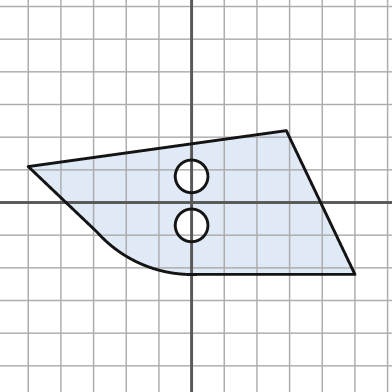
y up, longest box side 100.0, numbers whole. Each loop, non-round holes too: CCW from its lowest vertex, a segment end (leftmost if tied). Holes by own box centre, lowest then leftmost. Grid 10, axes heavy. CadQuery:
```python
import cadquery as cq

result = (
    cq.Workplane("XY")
    .moveTo(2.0, -22.0)
    .lineTo(50.0, -22.0)
    .lineTo(29.0, 22.0)
    .lineTo(-50.0, 11.0)
    .lineTo(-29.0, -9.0)
    .threePointArc((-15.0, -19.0), (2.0, -22.0))
    .close()
    .moveTo(0.0, -7.0)
    .circle(5.0)
    .moveTo(0.0, 8.0)
    .circle(5.0)
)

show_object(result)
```